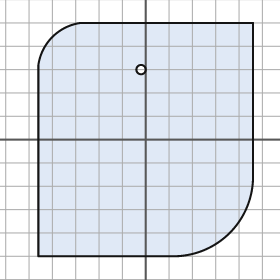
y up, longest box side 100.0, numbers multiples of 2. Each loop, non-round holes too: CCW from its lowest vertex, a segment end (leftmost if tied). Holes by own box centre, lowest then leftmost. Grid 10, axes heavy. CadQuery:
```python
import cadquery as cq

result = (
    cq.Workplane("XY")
    .moveTo(-46.0, -50.0)
    .lineTo(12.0, -50.0)
    .threePointArc((36.0, -40.0), (46.0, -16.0))
    .lineTo(46.0, 50.0)
    .lineTo(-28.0, 50.0)
    .threePointArc((-40.0, 44.0), (-46.0, 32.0))
    .close()
    .moveTo(-2.0, 30.0)
    .circle(2.0)
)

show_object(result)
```